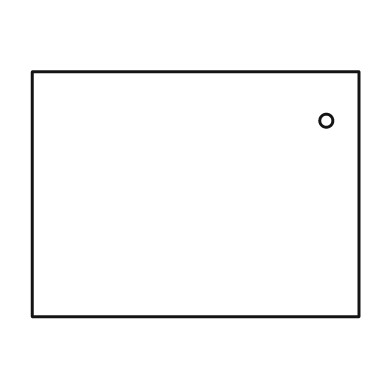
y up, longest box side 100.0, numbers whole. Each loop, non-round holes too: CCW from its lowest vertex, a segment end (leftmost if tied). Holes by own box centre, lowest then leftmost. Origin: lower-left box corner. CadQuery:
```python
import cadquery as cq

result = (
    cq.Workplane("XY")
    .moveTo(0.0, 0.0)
    .lineTo(100.0, 0.0)
    .lineTo(100.0, 75.0)
    .lineTo(0.0, 75.0)
    .close()
    .moveTo(90.0, 60.0)
    .circle(2.0)
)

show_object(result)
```